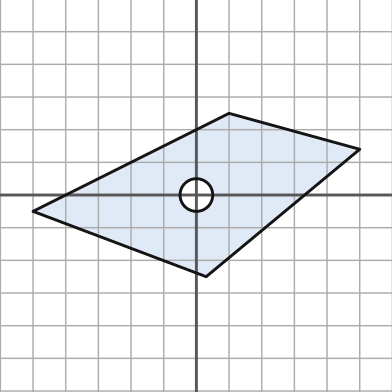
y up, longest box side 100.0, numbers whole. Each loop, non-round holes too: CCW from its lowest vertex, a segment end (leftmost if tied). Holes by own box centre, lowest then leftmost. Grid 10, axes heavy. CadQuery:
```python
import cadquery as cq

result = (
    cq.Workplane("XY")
    .moveTo(3.0, -25.0)
    .lineTo(50.0, 14.0)
    .lineTo(10.0, 25.0)
    .lineTo(-50.0, -5.0)
    .close()
    .moveTo(0.0, 0.0)
    .circle(5.0)
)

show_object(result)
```